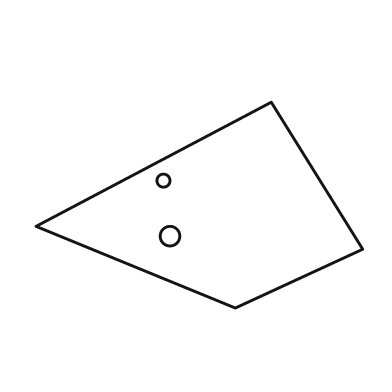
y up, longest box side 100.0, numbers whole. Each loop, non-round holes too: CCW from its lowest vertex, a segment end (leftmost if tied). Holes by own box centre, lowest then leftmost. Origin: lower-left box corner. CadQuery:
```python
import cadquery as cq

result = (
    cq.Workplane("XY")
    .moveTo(61.0, 0.0)
    .lineTo(100.0, 18.0)
    .lineTo(72.0, 63.0)
    .lineTo(0.0, 25.0)
    .close()
    .moveTo(41.0, 22.0)
    .circle(3.0)
    .moveTo(39.0, 39.0)
    .circle(2.0)
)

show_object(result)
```